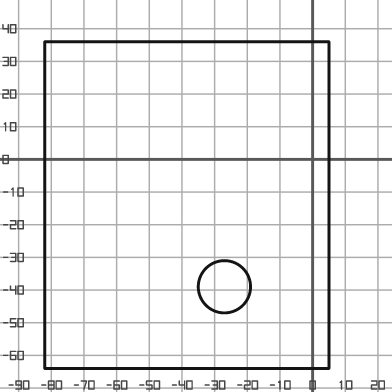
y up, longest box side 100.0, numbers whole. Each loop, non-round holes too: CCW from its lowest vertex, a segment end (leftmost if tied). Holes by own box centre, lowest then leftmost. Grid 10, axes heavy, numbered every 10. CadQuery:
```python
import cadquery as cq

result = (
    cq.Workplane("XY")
    .moveTo(-82.0, -64.0)
    .lineTo(5.0, -64.0)
    .lineTo(5.0, 36.0)
    .lineTo(-82.0, 36.0)
    .close()
    .moveTo(-27.0, -39.0)
    .circle(8.0)
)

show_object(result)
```